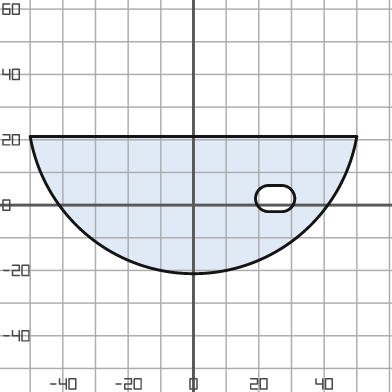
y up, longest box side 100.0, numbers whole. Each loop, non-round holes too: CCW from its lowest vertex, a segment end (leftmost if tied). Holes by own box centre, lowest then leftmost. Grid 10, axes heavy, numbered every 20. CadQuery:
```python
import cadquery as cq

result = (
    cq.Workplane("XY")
    .moveTo(-50.0, 21.0)
    .threePointArc((0.0, -21.0), (50.0, 21.0))
    .close()
    .moveTo(23.0, -2.0)
    .lineTo(27.0, -2.0)
    .threePointArc((31.0, 2.0), (27.0, 6.0))
    .lineTo(23.0, 6.0)
    .threePointArc((19.0, 2.0), (23.0, -2.0))
    .close()
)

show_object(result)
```